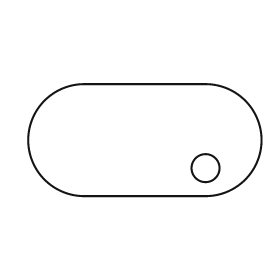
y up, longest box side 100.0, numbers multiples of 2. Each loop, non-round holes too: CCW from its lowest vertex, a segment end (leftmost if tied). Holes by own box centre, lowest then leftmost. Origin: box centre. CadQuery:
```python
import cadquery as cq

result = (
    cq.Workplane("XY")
    .moveTo(-26.0, -24.0)
    .lineTo(26.0, -24.0)
    .threePointArc((50.0, 0.0), (26.0, 24.0))
    .lineTo(-26.0, 24.0)
    .threePointArc((-50.0, 0.0), (-26.0, -24.0))
    .close()
    .moveTo(26.0, -12.0)
    .circle(6.0)
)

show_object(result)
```